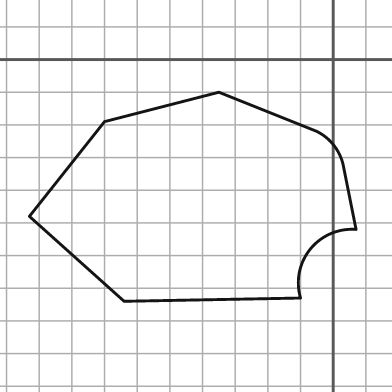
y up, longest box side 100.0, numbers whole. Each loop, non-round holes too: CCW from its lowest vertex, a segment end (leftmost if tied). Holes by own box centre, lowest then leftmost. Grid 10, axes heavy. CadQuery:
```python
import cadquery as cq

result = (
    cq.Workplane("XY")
    .moveTo(-64.0, -74.0)
    .lineTo(-10.0, -73.0)
    .threePointArc((-7.0, -58.0), (7.0, -52.0))
    .lineTo(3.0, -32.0)
    .threePointArc((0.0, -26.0), (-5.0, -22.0))
    .lineTo(-35.0, -10.0)
    .lineTo(-70.0, -19.0)
    .lineTo(-93.0, -48.0)
    .close()
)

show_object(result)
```